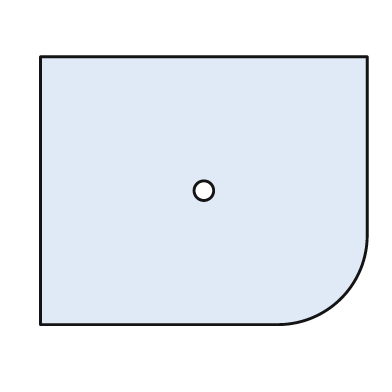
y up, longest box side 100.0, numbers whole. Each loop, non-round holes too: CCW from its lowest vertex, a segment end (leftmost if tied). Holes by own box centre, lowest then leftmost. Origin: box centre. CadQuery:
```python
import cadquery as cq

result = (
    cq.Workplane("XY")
    .moveTo(-50.0, -41.0)
    .lineTo(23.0, -41.0)
    .threePointArc((42.0, -33.0), (50.0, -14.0))
    .lineTo(50.0, 41.0)
    .lineTo(-50.0, 41.0)
    .close()
    .moveTo(0.0, 0.0)
    .circle(3.0)
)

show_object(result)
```